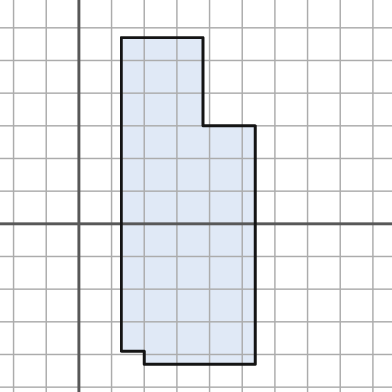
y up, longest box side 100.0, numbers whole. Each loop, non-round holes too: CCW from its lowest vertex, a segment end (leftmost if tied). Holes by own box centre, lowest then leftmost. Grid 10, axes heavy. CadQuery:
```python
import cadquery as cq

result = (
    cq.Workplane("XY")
    .moveTo(20.0, -43.0)
    .lineTo(54.0, -43.0)
    .lineTo(54.0, 30.0)
    .lineTo(38.0, 30.0)
    .lineTo(38.0, 57.0)
    .lineTo(13.0, 57.0)
    .lineTo(13.0, -39.0)
    .lineTo(20.0, -39.0)
    .close()
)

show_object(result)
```